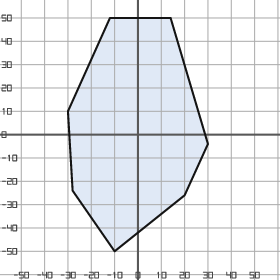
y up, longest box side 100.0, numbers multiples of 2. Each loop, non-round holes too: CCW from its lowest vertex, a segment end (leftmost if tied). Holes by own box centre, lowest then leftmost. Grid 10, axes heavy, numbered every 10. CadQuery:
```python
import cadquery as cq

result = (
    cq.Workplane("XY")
    .moveTo(-10.0, -50.0)
    .lineTo(20.0, -26.0)
    .lineTo(30.0, -4.0)
    .lineTo(14.0, 50.0)
    .lineTo(-12.0, 50.0)
    .lineTo(-30.0, 10.0)
    .lineTo(-28.0, -24.0)
    .close()
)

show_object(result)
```